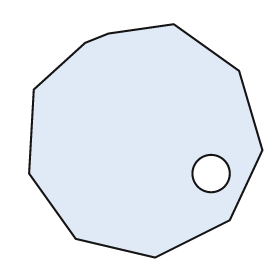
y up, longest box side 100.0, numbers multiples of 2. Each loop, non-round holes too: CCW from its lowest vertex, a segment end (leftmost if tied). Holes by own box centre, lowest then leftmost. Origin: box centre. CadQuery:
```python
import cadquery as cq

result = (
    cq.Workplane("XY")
    .moveTo(4.0, -50.0)
    .lineTo(36.0, -34.0)
    .lineTo(50.0, -4.0)
    .lineTo(40.0, 30.0)
    .lineTo(12.0, 50.0)
    .lineTo(-16.0, 46.0)
    .lineTo(-26.0, 42.0)
    .lineTo(-48.0, 22.0)
    .lineTo(-50.0, -14.0)
    .lineTo(-30.0, -42.0)
    .close()
    .moveTo(28.0, -14.0)
    .circle(8.0)
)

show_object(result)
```